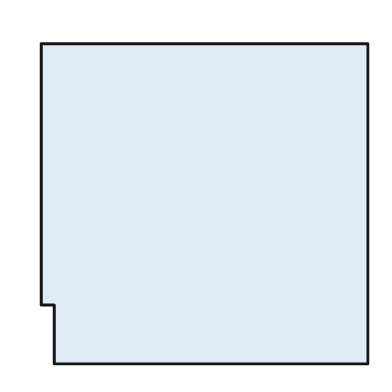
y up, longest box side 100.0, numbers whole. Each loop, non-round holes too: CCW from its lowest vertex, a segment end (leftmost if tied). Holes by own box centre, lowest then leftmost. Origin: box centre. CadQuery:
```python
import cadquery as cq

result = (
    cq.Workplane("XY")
    .moveTo(-46.0, -49.0)
    .lineTo(50.0, -49.0)
    .lineTo(50.0, 49.0)
    .lineTo(-50.0, 49.0)
    .lineTo(-50.0, -31.0)
    .lineTo(-46.0, -31.0)
    .close()
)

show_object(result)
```